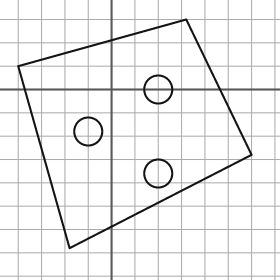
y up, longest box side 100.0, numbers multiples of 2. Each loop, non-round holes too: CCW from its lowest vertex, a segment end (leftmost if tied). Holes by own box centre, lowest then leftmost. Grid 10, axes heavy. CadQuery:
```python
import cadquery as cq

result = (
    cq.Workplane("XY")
    .moveTo(-18.0, -68.0)
    .lineTo(60.0, -28.0)
    .lineTo(32.0, 30.0)
    .lineTo(-40.0, 10.0)
    .close()
    .moveTo(20.0, -36.0)
    .circle(6.0)
    .moveTo(-10.0, -18.0)
    .circle(6.0)
    .moveTo(20.0, 0.0)
    .circle(6.0)
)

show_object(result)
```